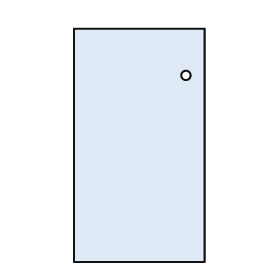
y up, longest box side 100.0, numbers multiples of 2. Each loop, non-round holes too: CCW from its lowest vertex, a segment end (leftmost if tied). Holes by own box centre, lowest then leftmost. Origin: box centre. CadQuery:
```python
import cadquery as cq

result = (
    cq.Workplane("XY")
    .moveTo(-28.0, -50.0)
    .lineTo(28.0, -50.0)
    .lineTo(28.0, 50.0)
    .lineTo(-28.0, 50.0)
    .close()
    .moveTo(20.0, 30.0)
    .circle(2.0)
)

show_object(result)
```